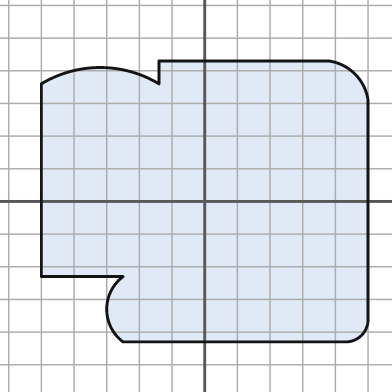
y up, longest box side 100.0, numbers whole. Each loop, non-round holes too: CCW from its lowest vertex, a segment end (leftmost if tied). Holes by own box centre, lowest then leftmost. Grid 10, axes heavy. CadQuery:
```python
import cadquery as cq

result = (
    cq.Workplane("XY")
    .moveTo(-25.0, -43.0)
    .lineTo(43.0, -43.0)
    .threePointArc((48.0, -41.0), (50.0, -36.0))
    .lineTo(50.0, 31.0)
    .threePointArc((46.0, 39.0), (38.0, 43.0))
    .lineTo(-14.0, 43.0)
    .lineTo(-14.0, 36.0)
    .threePointArc((-32.0, 41.0), (-50.0, 36.0))
    .lineTo(-50.0, -23.0)
    .lineTo(-25.0, -23.0)
    .threePointArc((-30.0, -33.0), (-25.0, -43.0))
    .close()
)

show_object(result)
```